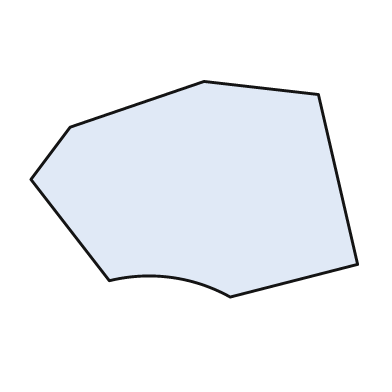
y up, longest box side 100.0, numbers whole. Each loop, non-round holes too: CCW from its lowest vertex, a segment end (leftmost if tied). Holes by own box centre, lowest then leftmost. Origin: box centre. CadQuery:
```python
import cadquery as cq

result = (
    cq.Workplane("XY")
    .moveTo(11.0, -33.0)
    .lineTo(50.0, -23.0)
    .lineTo(38.0, 29.0)
    .lineTo(3.0, 33.0)
    .lineTo(-38.0, 19.0)
    .lineTo(-50.0, 3.0)
    .lineTo(-26.0, -28.0)
    .threePointArc((-7.0, -27.0), (11.0, -33.0))
    .close()
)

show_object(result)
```